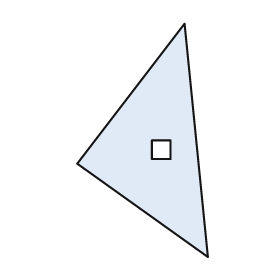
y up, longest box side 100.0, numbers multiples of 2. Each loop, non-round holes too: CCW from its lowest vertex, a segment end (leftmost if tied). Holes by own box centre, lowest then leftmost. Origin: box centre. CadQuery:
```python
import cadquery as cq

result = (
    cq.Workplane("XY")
    .moveTo(28.0, -50.0)
    .lineTo(18.0, 50.0)
    .lineTo(-28.0, -10.0)
    .close()
    .moveTo(4.0, -8.0)
    .lineTo(12.0, -8.0)
    .lineTo(12.0, 0.0)
    .lineTo(4.0, 0.0)
    .close()
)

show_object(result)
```